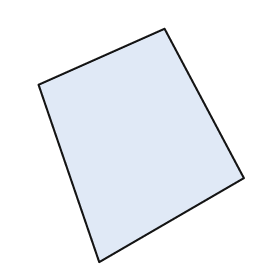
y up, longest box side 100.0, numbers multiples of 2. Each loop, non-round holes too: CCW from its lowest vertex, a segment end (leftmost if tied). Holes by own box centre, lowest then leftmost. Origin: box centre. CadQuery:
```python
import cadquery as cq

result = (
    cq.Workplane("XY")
    .moveTo(-18.0, -50.0)
    .lineTo(44.0, -14.0)
    .lineTo(10.0, 50.0)
    .lineTo(-44.0, 26.0)
    .close()
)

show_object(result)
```